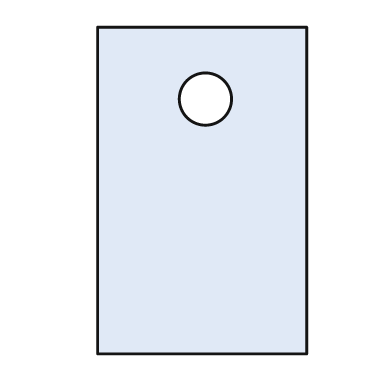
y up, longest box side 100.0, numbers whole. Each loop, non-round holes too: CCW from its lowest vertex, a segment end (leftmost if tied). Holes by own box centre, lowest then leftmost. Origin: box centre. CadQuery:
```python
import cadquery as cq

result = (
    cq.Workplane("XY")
    .moveTo(-32.0, -50.0)
    .lineTo(32.0, -50.0)
    .lineTo(32.0, 50.0)
    .lineTo(-32.0, 50.0)
    .close()
    .moveTo(1.0, 28.0)
    .circle(8.0)
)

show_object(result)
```